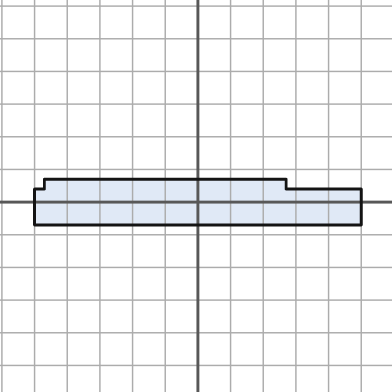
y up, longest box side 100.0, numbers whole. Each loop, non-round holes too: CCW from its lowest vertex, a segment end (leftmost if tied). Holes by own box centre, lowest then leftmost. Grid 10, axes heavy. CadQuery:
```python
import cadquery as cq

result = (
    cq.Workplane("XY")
    .moveTo(-50.0, -7.0)
    .lineTo(50.0, -7.0)
    .lineTo(50.0, 4.0)
    .lineTo(27.0, 4.0)
    .lineTo(27.0, 7.0)
    .lineTo(-47.0, 7.0)
    .lineTo(-47.0, 4.0)
    .lineTo(-50.0, 4.0)
    .close()
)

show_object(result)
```